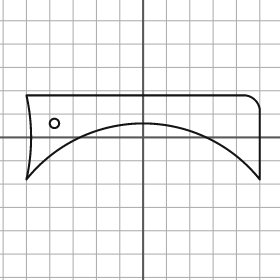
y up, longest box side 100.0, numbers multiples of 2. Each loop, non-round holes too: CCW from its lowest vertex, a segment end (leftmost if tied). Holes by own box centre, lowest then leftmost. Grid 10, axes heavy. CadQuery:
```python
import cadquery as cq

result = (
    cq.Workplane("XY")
    .moveTo(-50.0, -18.0)
    .threePointArc((0.0, 6.0), (50.0, -18.0))
    .lineTo(50.0, 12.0)
    .threePointArc((48.0, 16.0), (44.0, 18.0))
    .lineTo(-50.0, 18.0)
    .threePointArc((-48.0, 0.0), (-50.0, -18.0))
    .close()
    .moveTo(-38.0, 6.0)
    .circle(2.0)
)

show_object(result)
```